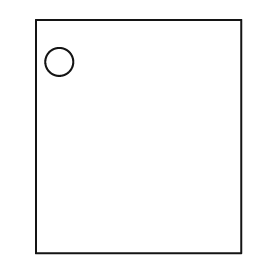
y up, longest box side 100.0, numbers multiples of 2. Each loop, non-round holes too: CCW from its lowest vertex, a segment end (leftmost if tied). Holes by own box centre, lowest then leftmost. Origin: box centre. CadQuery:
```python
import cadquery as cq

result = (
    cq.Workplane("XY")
    .moveTo(-44.0, -50.0)
    .lineTo(44.0, -50.0)
    .lineTo(44.0, 50.0)
    .lineTo(-44.0, 50.0)
    .close()
    .moveTo(-34.0, 32.0)
    .circle(6.0)
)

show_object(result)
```